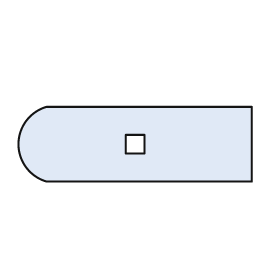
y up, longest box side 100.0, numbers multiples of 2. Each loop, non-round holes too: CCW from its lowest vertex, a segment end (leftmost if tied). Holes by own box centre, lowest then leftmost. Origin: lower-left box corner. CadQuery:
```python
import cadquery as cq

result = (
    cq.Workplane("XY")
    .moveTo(12.0, 0.0)
    .lineTo(100.0, 0.0)
    .lineTo(100.0, 32.0)
    .lineTo(12.0, 32.0)
    .threePointArc((0.0, 16.0), (12.0, 0.0))
    .close()
    .moveTo(46.0, 12.0)
    .lineTo(54.0, 12.0)
    .lineTo(54.0, 20.0)
    .lineTo(46.0, 20.0)
    .close()
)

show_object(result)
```